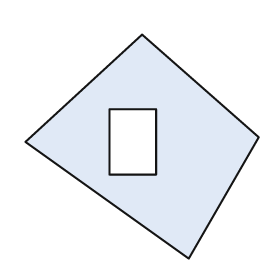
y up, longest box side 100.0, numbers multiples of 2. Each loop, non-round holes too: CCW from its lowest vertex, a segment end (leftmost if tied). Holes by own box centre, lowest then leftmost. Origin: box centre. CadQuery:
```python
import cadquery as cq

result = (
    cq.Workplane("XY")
    .moveTo(20.0, -48.0)
    .lineTo(50.0, 4.0)
    .lineTo(0.0, 48.0)
    .lineTo(-50.0, 2.0)
    .close()
    .moveTo(-14.0, -12.0)
    .lineTo(6.0, -12.0)
    .lineTo(6.0, 16.0)
    .lineTo(-14.0, 16.0)
    .close()
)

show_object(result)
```